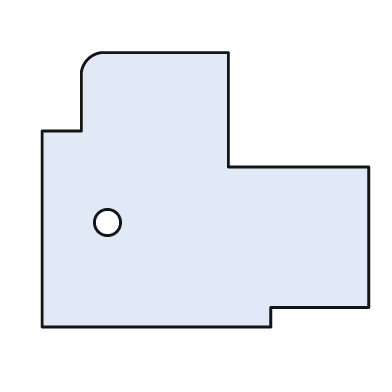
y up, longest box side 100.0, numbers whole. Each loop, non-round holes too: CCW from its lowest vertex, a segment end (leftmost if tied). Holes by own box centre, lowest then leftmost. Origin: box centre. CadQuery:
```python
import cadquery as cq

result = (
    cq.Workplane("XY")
    .moveTo(-50.0, -42.0)
    .lineTo(20.0, -42.0)
    .lineTo(20.0, -36.0)
    .lineTo(50.0, -36.0)
    .lineTo(50.0, 7.0)
    .lineTo(7.0, 7.0)
    .lineTo(7.0, 42.0)
    .lineTo(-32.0, 42.0)
    .threePointArc((-36.0, 40.0), (-38.0, 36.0))
    .lineTo(-38.0, 18.0)
    .lineTo(-50.0, 18.0)
    .close()
    .moveTo(-30.0, -10.0)
    .circle(4.0)
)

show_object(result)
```